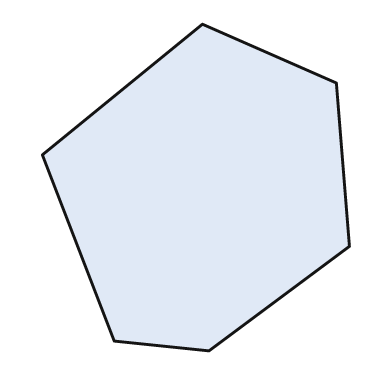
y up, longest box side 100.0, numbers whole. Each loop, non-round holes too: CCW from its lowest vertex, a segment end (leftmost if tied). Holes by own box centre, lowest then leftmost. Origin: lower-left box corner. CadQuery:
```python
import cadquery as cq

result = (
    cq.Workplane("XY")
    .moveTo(51.0, 0.0)
    .lineTo(94.0, 32.0)
    .lineTo(90.0, 82.0)
    .lineTo(49.0, 100.0)
    .lineTo(0.0, 60.0)
    .lineTo(22.0, 3.0)
    .close()
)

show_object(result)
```